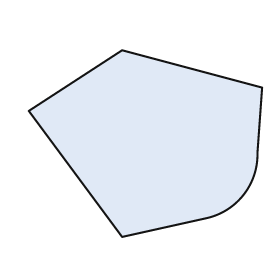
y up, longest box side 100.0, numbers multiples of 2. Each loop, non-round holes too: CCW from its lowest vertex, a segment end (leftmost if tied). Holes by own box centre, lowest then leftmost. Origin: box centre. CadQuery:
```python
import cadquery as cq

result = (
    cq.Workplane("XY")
    .moveTo(-10.0, -40.0)
    .lineTo(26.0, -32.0)
    .threePointArc((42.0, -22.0), (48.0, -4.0))
    .lineTo(50.0, 24.0)
    .lineTo(-10.0, 40.0)
    .lineTo(-50.0, 14.0)
    .close()
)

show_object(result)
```